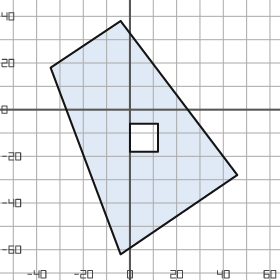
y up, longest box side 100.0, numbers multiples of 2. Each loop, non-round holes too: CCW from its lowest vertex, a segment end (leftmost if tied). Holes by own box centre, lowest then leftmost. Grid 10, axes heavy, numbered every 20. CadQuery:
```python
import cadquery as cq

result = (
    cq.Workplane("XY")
    .moveTo(-4.0, -62.0)
    .lineTo(46.0, -28.0)
    .lineTo(-4.0, 38.0)
    .lineTo(-34.0, 18.0)
    .close()
    .moveTo(0.0, -18.0)
    .lineTo(12.0, -18.0)
    .lineTo(12.0, -6.0)
    .lineTo(0.0, -6.0)
    .close()
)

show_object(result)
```